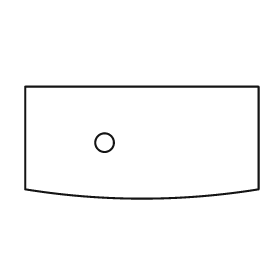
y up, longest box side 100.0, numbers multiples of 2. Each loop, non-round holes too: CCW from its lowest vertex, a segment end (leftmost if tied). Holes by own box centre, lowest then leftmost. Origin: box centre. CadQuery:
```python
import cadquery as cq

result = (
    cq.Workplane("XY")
    .moveTo(-50.0, -20.0)
    .threePointArc((0.0, -24.0), (50.0, -20.0))
    .lineTo(50.0, 24.0)
    .lineTo(-50.0, 24.0)
    .close()
    .moveTo(-16.0, 0.0)
    .circle(4.0)
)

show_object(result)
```